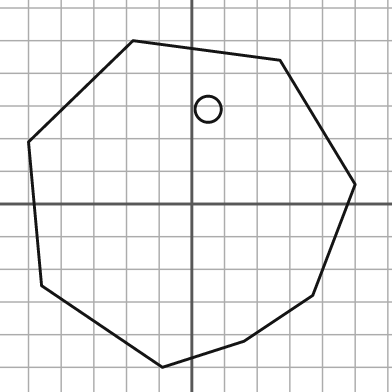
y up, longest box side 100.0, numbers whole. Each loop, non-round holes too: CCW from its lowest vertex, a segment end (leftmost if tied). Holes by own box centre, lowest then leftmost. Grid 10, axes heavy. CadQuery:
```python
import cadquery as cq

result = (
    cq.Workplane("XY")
    .moveTo(-9.0, -50.0)
    .lineTo(16.0, -42.0)
    .lineTo(37.0, -28.0)
    .lineTo(50.0, 6.0)
    .lineTo(27.0, 44.0)
    .lineTo(-18.0, 50.0)
    .lineTo(-50.0, 19.0)
    .lineTo(-46.0, -25.0)
    .close()
    .moveTo(5.0, 29.0)
    .circle(4.0)
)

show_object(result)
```